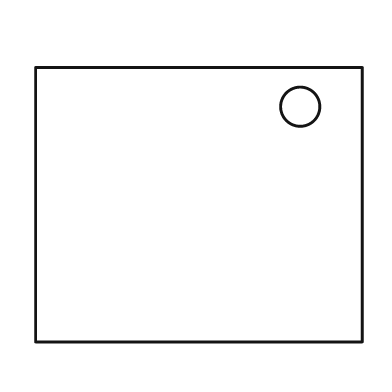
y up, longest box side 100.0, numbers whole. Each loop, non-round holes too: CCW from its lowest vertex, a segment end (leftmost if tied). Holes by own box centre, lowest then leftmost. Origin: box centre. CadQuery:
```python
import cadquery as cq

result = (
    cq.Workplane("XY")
    .moveTo(-50.0, -42.0)
    .lineTo(50.0, -42.0)
    .lineTo(50.0, 42.0)
    .lineTo(-50.0, 42.0)
    .close()
    .moveTo(31.0, 30.0)
    .circle(6.0)
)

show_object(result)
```